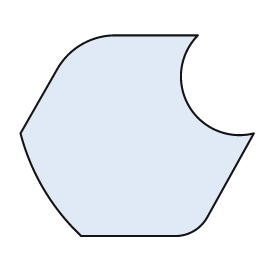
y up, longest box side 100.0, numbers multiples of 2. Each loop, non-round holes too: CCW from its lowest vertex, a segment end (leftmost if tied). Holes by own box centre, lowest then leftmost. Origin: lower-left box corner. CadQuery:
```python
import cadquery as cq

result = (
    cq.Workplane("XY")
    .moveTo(26.0, 0.0)
    .lineTo(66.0, 0.0)
    .threePointArc((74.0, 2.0), (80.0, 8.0))
    .lineTo(100.0, 44.0)
    .threePointArc((72.0, 56.0), (76.0, 86.0))
    .lineTo(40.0, 86.0)
    .threePointArc((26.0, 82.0), (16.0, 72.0))
    .lineTo(0.0, 44.0)
    .threePointArc((10.0, 20.0), (26.0, 0.0))
    .close()
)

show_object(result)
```